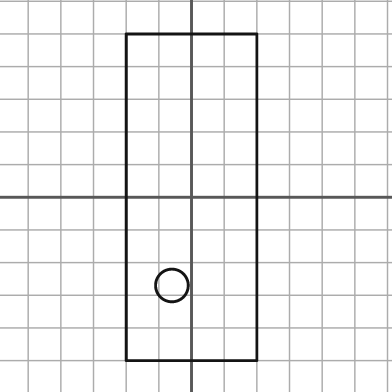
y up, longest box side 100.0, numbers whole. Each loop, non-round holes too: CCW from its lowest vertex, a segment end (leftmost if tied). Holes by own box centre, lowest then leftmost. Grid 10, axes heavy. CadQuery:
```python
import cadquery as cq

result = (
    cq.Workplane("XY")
    .moveTo(-20.0, -50.0)
    .lineTo(20.0, -50.0)
    .lineTo(20.0, 50.0)
    .lineTo(-20.0, 50.0)
    .close()
    .moveTo(-6.0, -27.0)
    .circle(5.0)
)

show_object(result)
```